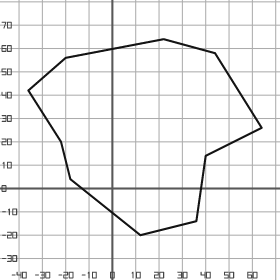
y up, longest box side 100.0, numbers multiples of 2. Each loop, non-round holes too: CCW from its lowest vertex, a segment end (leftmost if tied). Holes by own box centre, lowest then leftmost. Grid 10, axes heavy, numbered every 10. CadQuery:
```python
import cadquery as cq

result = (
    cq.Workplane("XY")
    .moveTo(12.0, -20.0)
    .lineTo(36.0, -14.0)
    .lineTo(40.0, 14.0)
    .lineTo(64.0, 26.0)
    .lineTo(44.0, 58.0)
    .lineTo(22.0, 64.0)
    .lineTo(-20.0, 56.0)
    .lineTo(-36.0, 42.0)
    .lineTo(-22.0, 20.0)
    .lineTo(-18.0, 4.0)
    .close()
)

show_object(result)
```